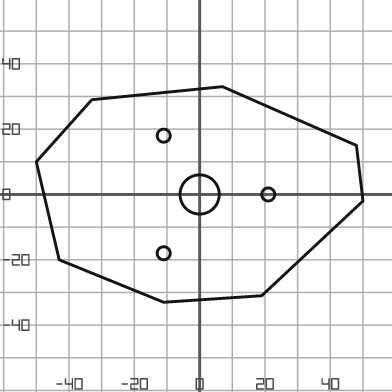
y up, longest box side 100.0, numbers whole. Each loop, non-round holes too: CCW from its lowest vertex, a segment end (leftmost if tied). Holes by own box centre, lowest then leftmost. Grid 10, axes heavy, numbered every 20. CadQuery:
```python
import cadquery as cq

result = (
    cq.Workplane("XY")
    .moveTo(-11.0, -33.0)
    .lineTo(19.0, -31.0)
    .lineTo(50.0, -2.0)
    .lineTo(48.0, 15.0)
    .lineTo(7.0, 33.0)
    .lineTo(-33.0, 29.0)
    .lineTo(-50.0, 10.0)
    .lineTo(-43.0, -20.0)
    .close()
    .moveTo(-11.0, -18.0)
    .circle(2.0)
    .moveTo(0.0, 0.0)
    .circle(6.0)
    .moveTo(21.0, 0.0)
    .circle(2.0)
    .moveTo(-11.0, 18.0)
    .circle(2.0)
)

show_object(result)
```